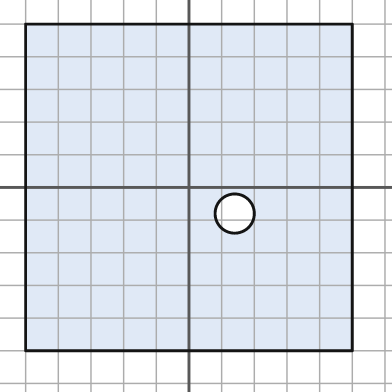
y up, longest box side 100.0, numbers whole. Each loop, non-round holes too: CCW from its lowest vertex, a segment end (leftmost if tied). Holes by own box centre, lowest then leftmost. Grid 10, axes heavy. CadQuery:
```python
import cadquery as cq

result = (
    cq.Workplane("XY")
    .moveTo(-50.0, -50.0)
    .lineTo(50.0, -50.0)
    .lineTo(50.0, 50.0)
    .lineTo(-50.0, 50.0)
    .close()
    .moveTo(14.0, -8.0)
    .circle(6.0)
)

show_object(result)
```